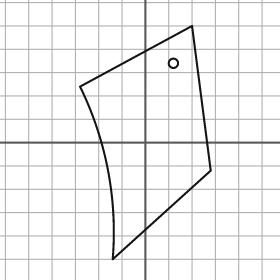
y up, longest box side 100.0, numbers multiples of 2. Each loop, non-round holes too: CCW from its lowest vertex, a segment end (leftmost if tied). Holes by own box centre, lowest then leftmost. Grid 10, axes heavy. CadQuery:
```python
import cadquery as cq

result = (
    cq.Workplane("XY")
    .moveTo(-14.0, -50.0)
    .lineTo(28.0, -12.0)
    .lineTo(20.0, 50.0)
    .lineTo(-28.0, 24.0)
    .threePointArc((-16.0, -12.0), (-14.0, -50.0))
    .close()
    .moveTo(12.0, 34.0)
    .circle(2.0)
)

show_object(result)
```